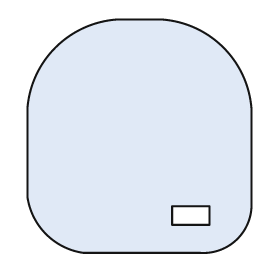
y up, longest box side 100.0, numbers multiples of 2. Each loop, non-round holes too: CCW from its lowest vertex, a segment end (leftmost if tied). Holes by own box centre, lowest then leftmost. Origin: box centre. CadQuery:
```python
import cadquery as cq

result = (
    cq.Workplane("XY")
    .moveTo(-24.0, -50.0)
    .lineTo(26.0, -50.0)
    .threePointArc((42.0, -44.0), (48.0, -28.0))
    .lineTo(48.0, 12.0)
    .threePointArc((36.0, 38.0), (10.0, 50.0))
    .lineTo(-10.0, 50.0)
    .threePointArc((-36.0, 38.0), (-48.0, 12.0))
    .lineTo(-48.0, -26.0)
    .threePointArc((-40.0, -42.0), (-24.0, -50.0))
    .close()
    .moveTo(14.0, -38.0)
    .lineTo(30.0, -38.0)
    .lineTo(30.0, -30.0)
    .lineTo(14.0, -30.0)
    .close()
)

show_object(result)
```